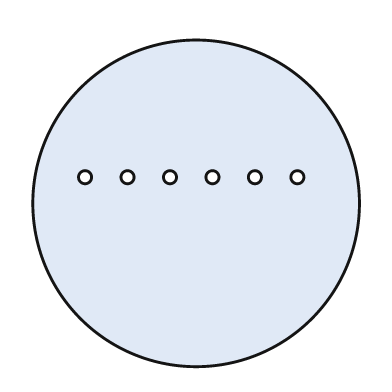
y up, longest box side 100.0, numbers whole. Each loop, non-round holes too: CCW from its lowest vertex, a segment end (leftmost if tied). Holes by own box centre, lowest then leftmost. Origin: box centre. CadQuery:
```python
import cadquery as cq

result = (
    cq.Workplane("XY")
    .moveTo(0.0, 0.0)
    .circle(50.0)
    .moveTo(-34.0, 8.0)
    .circle(2.0)
    .moveTo(-21.0, 8.0)
    .circle(2.0)
    .moveTo(-8.0, 8.0)
    .circle(2.0)
    .moveTo(5.0, 8.0)
    .circle(2.0)
    .moveTo(18.0, 8.0)
    .circle(2.0)
    .moveTo(31.0, 8.0)
    .circle(2.0)
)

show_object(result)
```